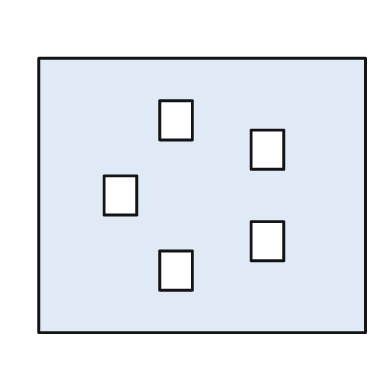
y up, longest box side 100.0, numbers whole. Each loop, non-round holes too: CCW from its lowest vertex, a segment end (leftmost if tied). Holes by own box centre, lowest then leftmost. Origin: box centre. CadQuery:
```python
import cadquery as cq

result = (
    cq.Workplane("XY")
    .moveTo(-50.0, -42.0)
    .lineTo(50.0, -42.0)
    .lineTo(50.0, 42.0)
    .lineTo(-50.0, 42.0)
    .close()
    .moveTo(-13.0, -29.0)
    .lineTo(-3.0, -29.0)
    .lineTo(-3.0, -17.0)
    .lineTo(-13.0, -17.0)
    .close()
    .moveTo(15.0, -20.0)
    .lineTo(25.0, -20.0)
    .lineTo(25.0, -8.0)
    .lineTo(15.0, -8.0)
    .close()
    .moveTo(-30.0, -6.0)
    .lineTo(-20.0, -6.0)
    .lineTo(-20.0, 6.0)
    .lineTo(-30.0, 6.0)
    .close()
    .moveTo(15.0, 8.0)
    .lineTo(25.0, 8.0)
    .lineTo(25.0, 20.0)
    .lineTo(15.0, 20.0)
    .close()
    .moveTo(-13.0, 17.0)
    .lineTo(-3.0, 17.0)
    .lineTo(-3.0, 29.0)
    .lineTo(-13.0, 29.0)
    .close()
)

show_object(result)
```